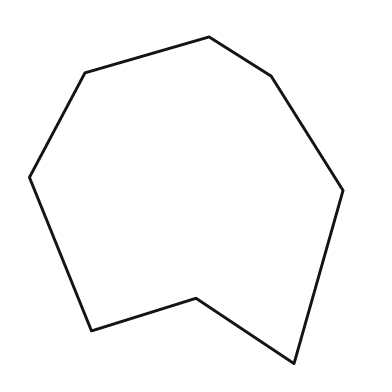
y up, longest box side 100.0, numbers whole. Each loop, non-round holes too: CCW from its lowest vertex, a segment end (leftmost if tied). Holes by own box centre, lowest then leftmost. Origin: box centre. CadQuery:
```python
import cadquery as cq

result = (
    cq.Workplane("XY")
    .moveTo(33.0, -50.0)
    .lineTo(48.0, 3.0)
    .lineTo(26.0, 38.0)
    .lineTo(7.0, 50.0)
    .lineTo(-31.0, 39.0)
    .lineTo(-48.0, 7.0)
    .lineTo(-29.0, -40.0)
    .lineTo(3.0, -30.0)
    .close()
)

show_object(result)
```